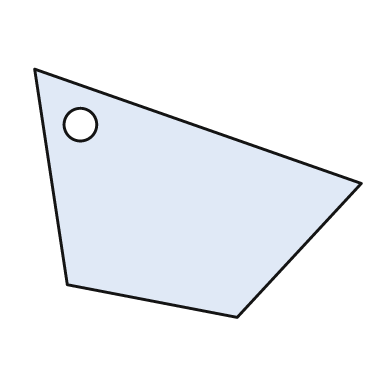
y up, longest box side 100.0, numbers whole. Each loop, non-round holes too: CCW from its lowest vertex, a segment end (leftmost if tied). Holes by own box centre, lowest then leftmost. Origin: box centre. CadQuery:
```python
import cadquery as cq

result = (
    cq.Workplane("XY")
    .moveTo(12.0, -38.0)
    .lineTo(50.0, 3.0)
    .lineTo(-50.0, 38.0)
    .lineTo(-40.0, -28.0)
    .close()
    .moveTo(-36.0, 21.0)
    .circle(5.0)
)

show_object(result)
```